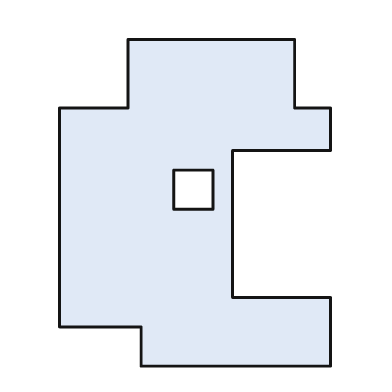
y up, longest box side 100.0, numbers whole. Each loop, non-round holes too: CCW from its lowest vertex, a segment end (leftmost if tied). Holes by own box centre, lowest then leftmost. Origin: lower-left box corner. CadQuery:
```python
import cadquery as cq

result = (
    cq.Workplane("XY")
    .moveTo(25.0, 0.0)
    .lineTo(83.0, 0.0)
    .lineTo(83.0, 21.0)
    .lineTo(53.0, 21.0)
    .lineTo(53.0, 66.0)
    .lineTo(83.0, 66.0)
    .lineTo(83.0, 79.0)
    .lineTo(72.0, 79.0)
    .lineTo(72.0, 100.0)
    .lineTo(21.0, 100.0)
    .lineTo(21.0, 79.0)
    .lineTo(0.0, 79.0)
    .lineTo(0.0, 12.0)
    .lineTo(25.0, 12.0)
    .close()
    .moveTo(35.0, 48.0)
    .lineTo(47.0, 48.0)
    .lineTo(47.0, 60.0)
    .lineTo(35.0, 60.0)
    .close()
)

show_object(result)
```